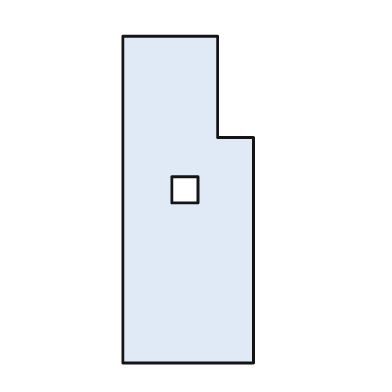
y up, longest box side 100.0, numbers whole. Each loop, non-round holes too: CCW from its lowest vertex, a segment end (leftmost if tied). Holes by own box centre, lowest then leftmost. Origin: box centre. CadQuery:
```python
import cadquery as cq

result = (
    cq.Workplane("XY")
    .moveTo(-20.0, -50.0)
    .lineTo(20.0, -50.0)
    .lineTo(20.0, 19.0)
    .lineTo(9.0, 19.0)
    .lineTo(9.0, 50.0)
    .lineTo(-20.0, 50.0)
    .close()
    .moveTo(-5.0, -1.0)
    .lineTo(3.0, -1.0)
    .lineTo(3.0, 7.0)
    .lineTo(-5.0, 7.0)
    .close()
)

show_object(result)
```